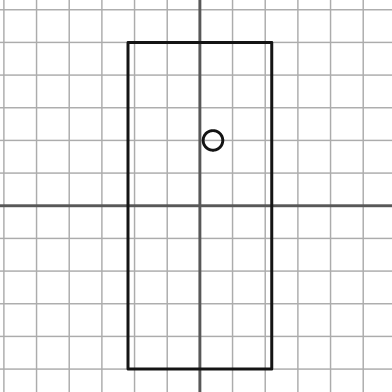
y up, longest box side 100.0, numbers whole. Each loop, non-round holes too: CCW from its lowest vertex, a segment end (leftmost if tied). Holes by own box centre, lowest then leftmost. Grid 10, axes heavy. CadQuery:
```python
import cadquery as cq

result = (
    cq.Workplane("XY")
    .moveTo(-22.0, -50.0)
    .lineTo(22.0, -50.0)
    .lineTo(22.0, 50.0)
    .lineTo(-22.0, 50.0)
    .close()
    .moveTo(4.0, 20.0)
    .circle(3.0)
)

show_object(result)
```